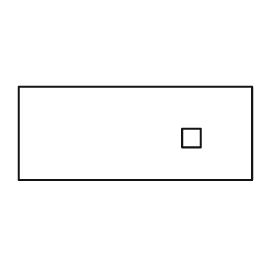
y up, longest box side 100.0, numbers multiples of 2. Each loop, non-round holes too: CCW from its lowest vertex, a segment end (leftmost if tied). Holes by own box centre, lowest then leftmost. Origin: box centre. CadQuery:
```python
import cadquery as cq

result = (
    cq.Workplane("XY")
    .moveTo(-50.0, -20.0)
    .lineTo(50.0, -20.0)
    .lineTo(50.0, 20.0)
    .lineTo(-50.0, 20.0)
    .close()
    .moveTo(20.0, -6.0)
    .lineTo(28.0, -6.0)
    .lineTo(28.0, 2.0)
    .lineTo(20.0, 2.0)
    .close()
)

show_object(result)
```